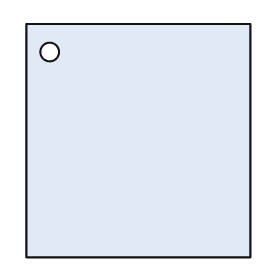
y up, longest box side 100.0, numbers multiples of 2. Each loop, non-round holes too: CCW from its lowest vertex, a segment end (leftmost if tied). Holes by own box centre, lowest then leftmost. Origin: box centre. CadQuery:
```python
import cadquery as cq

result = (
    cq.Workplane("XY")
    .moveTo(-48.0, -50.0)
    .lineTo(48.0, -50.0)
    .lineTo(48.0, 50.0)
    .lineTo(-48.0, 50.0)
    .close()
    .moveTo(-38.0, 38.0)
    .circle(4.0)
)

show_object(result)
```